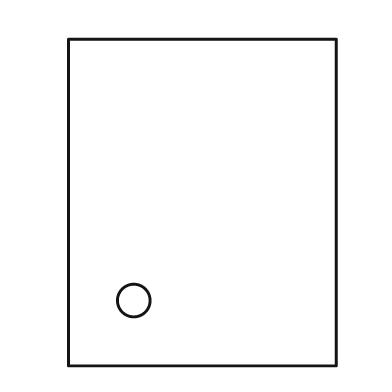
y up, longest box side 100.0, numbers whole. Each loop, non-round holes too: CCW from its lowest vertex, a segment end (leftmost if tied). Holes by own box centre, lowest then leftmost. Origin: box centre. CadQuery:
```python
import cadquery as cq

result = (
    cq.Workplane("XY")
    .moveTo(-41.0, -50.0)
    .lineTo(41.0, -50.0)
    .lineTo(41.0, 50.0)
    .lineTo(-41.0, 50.0)
    .close()
    .moveTo(-21.0, -30.0)
    .circle(5.0)
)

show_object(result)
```